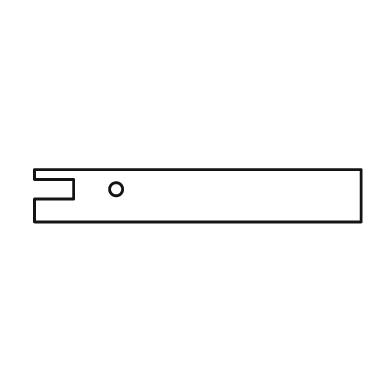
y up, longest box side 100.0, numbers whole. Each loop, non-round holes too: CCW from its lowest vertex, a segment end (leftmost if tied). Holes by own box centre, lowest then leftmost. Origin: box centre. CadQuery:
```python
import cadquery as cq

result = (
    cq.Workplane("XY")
    .moveTo(-50.0, -8.0)
    .lineTo(50.0, -8.0)
    .lineTo(50.0, 8.0)
    .lineTo(-50.0, 8.0)
    .lineTo(-50.0, 5.0)
    .lineTo(-38.0, 5.0)
    .lineTo(-38.0, -1.0)
    .lineTo(-50.0, -1.0)
    .close()
    .moveTo(-25.0, 2.0)
    .circle(2.0)
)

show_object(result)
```